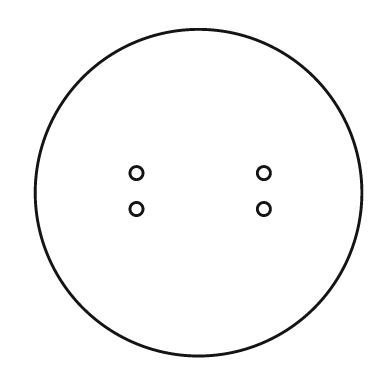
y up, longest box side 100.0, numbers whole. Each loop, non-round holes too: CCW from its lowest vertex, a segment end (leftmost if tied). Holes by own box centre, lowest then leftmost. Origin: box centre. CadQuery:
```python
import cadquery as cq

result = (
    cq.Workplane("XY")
    .moveTo(0.0, 0.0)
    .circle(50.0)
    .moveTo(-19.0, -5.0)
    .circle(2.0)
    .moveTo(20.0, -5.0)
    .circle(2.0)
    .moveTo(-19.0, 6.0)
    .circle(2.0)
    .moveTo(20.0, 6.0)
    .circle(2.0)
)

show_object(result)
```